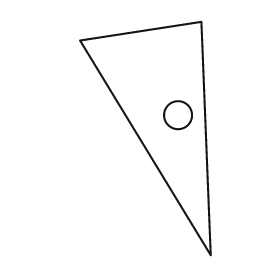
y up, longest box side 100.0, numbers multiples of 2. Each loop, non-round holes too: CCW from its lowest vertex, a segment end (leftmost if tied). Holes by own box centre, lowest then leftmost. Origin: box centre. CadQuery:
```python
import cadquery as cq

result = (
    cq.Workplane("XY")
    .moveTo(28.0, -50.0)
    .lineTo(24.0, 50.0)
    .lineTo(-28.0, 42.0)
    .close()
    .moveTo(14.0, 10.0)
    .circle(6.0)
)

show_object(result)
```